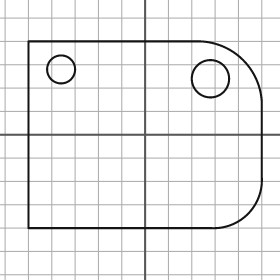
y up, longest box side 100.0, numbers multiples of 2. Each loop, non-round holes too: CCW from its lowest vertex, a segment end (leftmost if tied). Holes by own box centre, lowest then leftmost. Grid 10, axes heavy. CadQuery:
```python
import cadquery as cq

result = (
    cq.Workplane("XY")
    .moveTo(-50.0, -40.0)
    .lineTo(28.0, -40.0)
    .threePointArc((44.0, -34.0), (50.0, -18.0))
    .lineTo(50.0, 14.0)
    .threePointArc((42.0, 32.0), (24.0, 40.0))
    .lineTo(-50.0, 40.0)
    .close()
    .moveTo(28.0, 24.0)
    .circle(8.0)
    .moveTo(-36.0, 28.0)
    .circle(6.0)
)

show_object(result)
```